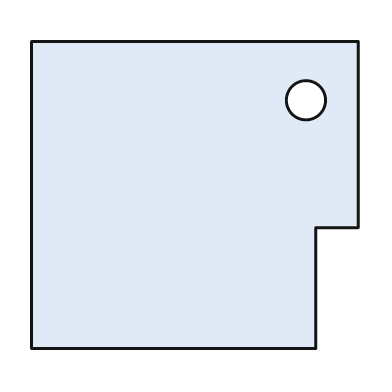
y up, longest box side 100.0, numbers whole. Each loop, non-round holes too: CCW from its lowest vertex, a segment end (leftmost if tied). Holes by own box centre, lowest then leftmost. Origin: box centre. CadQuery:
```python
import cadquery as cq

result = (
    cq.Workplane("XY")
    .moveTo(-50.0, -47.0)
    .lineTo(37.0, -47.0)
    .lineTo(37.0, -10.0)
    .lineTo(50.0, -10.0)
    .lineTo(50.0, 47.0)
    .lineTo(-50.0, 47.0)
    .close()
    .moveTo(34.0, 29.0)
    .circle(6.0)
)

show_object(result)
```